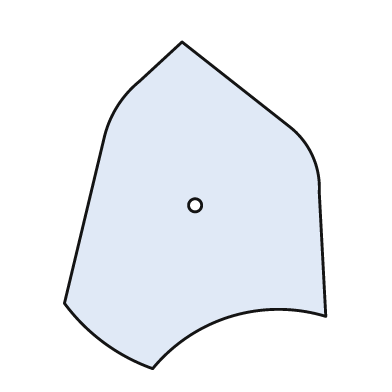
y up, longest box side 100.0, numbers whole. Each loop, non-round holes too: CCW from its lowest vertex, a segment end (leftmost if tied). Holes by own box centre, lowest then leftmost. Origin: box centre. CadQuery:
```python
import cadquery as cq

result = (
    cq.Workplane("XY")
    .moveTo(-13.0, -50.0)
    .threePointArc((11.0, -34.0), (40.0, -34.0))
    .lineTo(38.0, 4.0)
    .threePointArc((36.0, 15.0), (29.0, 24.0))
    .lineTo(-4.0, 50.0)
    .lineTo(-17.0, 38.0)
    .threePointArc((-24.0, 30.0), (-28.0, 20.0))
    .lineTo(-40.0, -30.0)
    .threePointArc((-28.0, -42.0), (-13.0, -50.0))
    .close()
    .moveTo(0.0, 0.0)
    .circle(2.0)
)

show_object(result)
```